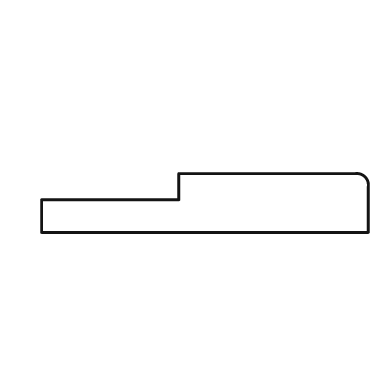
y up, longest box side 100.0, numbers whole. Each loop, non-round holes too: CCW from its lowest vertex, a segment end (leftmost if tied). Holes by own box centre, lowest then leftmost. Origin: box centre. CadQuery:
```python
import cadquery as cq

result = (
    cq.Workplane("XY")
    .moveTo(-50.0, -9.0)
    .lineTo(50.0, -9.0)
    .lineTo(50.0, 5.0)
    .threePointArc((49.0, 8.0), (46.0, 9.0))
    .lineTo(-8.0, 9.0)
    .lineTo(-8.0, 1.0)
    .lineTo(-50.0, 1.0)
    .close()
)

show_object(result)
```